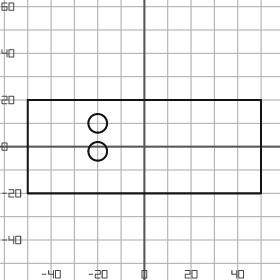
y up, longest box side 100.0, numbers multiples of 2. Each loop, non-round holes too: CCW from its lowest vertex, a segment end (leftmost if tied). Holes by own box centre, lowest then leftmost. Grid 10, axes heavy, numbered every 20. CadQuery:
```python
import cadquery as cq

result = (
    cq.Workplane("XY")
    .moveTo(-50.0, -20.0)
    .lineTo(50.0, -20.0)
    .lineTo(50.0, 20.0)
    .lineTo(-50.0, 20.0)
    .close()
    .moveTo(-20.0, -2.0)
    .circle(4.0)
    .moveTo(-20.0, 10.0)
    .circle(4.0)
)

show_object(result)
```